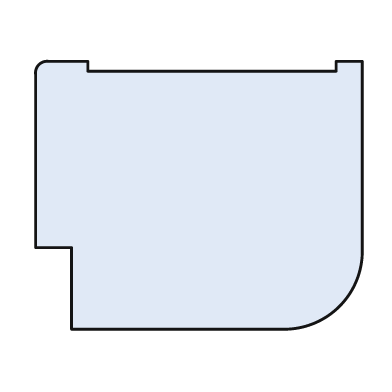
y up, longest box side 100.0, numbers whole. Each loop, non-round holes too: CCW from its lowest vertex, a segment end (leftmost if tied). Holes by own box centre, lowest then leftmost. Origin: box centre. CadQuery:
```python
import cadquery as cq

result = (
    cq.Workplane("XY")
    .moveTo(-39.0, -41.0)
    .lineTo(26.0, -41.0)
    .threePointArc((43.0, -34.0), (50.0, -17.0))
    .lineTo(50.0, 41.0)
    .lineTo(42.0, 41.0)
    .lineTo(42.0, 38.0)
    .lineTo(-34.0, 38.0)
    .lineTo(-34.0, 41.0)
    .lineTo(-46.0, 41.0)
    .threePointArc((-49.0, 40.0), (-50.0, 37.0))
    .lineTo(-50.0, -16.0)
    .lineTo(-39.0, -16.0)
    .close()
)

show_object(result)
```